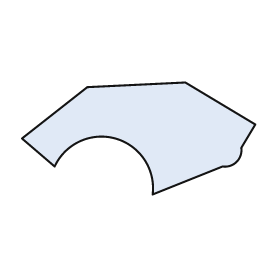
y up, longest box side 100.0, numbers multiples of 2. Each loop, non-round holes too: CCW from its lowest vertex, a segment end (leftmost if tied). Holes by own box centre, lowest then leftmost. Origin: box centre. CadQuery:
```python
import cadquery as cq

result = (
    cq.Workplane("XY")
    .moveTo(6.0, -24.0)
    .lineTo(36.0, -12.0)
    .threePointArc((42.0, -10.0), (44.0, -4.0))
    .lineTo(50.0, 6.0)
    .lineTo(20.0, 24.0)
    .lineTo(-22.0, 22.0)
    .lineTo(-50.0, 0.0)
    .lineTo(-36.0, -12.0)
    .threePointArc((-10.0, 0.0), (6.0, -24.0))
    .close()
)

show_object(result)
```